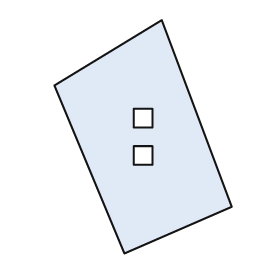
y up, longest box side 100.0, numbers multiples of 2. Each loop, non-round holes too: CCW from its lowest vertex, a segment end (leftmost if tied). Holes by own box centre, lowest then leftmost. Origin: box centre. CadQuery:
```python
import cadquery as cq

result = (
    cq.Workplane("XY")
    .moveTo(-8.0, -50.0)
    .lineTo(38.0, -30.0)
    .lineTo(8.0, 50.0)
    .lineTo(-38.0, 22.0)
    .close()
    .moveTo(-4.0, -12.0)
    .lineTo(4.0, -12.0)
    .lineTo(4.0, -4.0)
    .lineTo(-4.0, -4.0)
    .close()
    .moveTo(-4.0, 4.0)
    .lineTo(4.0, 4.0)
    .lineTo(4.0, 12.0)
    .lineTo(-4.0, 12.0)
    .close()
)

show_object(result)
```